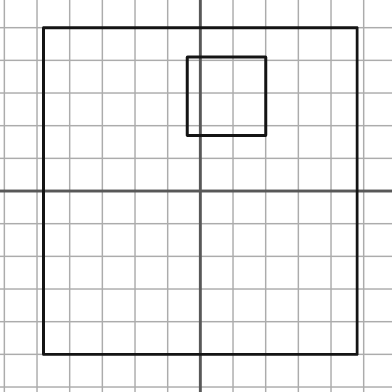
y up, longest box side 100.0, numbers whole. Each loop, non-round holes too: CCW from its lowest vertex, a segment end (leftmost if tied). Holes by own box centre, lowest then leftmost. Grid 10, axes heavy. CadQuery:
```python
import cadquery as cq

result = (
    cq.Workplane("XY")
    .moveTo(-48.0, -50.0)
    .lineTo(48.0, -50.0)
    .lineTo(48.0, 50.0)
    .lineTo(-48.0, 50.0)
    .close()
    .moveTo(-4.0, 17.0)
    .lineTo(20.0, 17.0)
    .lineTo(20.0, 41.0)
    .lineTo(-4.0, 41.0)
    .close()
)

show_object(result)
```